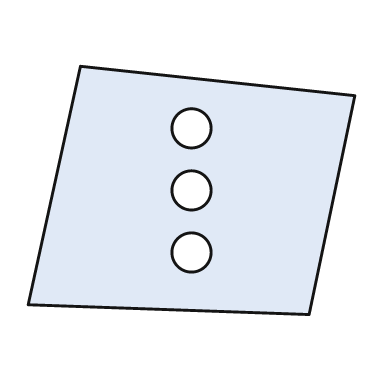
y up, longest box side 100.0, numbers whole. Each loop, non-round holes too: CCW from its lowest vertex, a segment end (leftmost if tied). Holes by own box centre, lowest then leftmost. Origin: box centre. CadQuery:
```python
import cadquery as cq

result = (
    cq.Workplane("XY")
    .moveTo(36.0, -38.0)
    .lineTo(50.0, 29.0)
    .lineTo(-34.0, 38.0)
    .lineTo(-50.0, -35.0)
    .close()
    .moveTo(0.0, -19.0)
    .circle(6.0)
    .moveTo(0.0, 0.0)
    .circle(6.0)
    .moveTo(0.0, 19.0)
    .circle(6.0)
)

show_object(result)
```